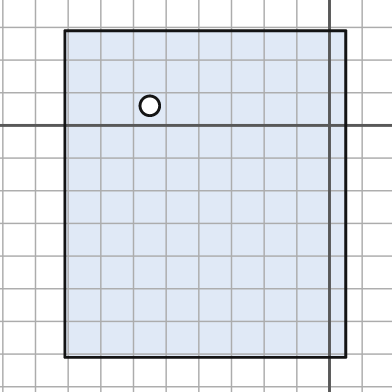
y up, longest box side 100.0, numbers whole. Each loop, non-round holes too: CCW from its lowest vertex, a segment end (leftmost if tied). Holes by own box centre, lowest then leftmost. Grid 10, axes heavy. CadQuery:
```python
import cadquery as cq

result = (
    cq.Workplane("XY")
    .moveTo(-81.0, -71.0)
    .lineTo(5.0, -71.0)
    .lineTo(5.0, 29.0)
    .lineTo(-81.0, 29.0)
    .close()
    .moveTo(-55.0, 6.0)
    .circle(3.0)
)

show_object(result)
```